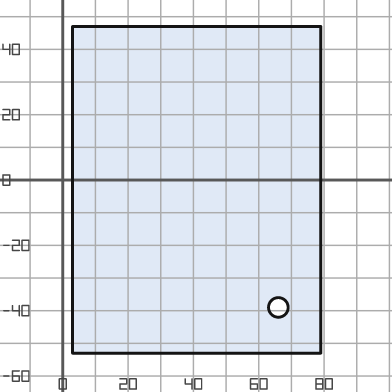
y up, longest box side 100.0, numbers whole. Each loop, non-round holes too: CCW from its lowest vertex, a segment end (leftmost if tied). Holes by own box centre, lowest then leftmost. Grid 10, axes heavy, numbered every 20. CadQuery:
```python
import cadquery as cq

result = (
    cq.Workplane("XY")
    .moveTo(3.0, -53.0)
    .lineTo(79.0, -53.0)
    .lineTo(79.0, 47.0)
    .lineTo(3.0, 47.0)
    .close()
    .moveTo(66.0, -39.0)
    .circle(3.0)
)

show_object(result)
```